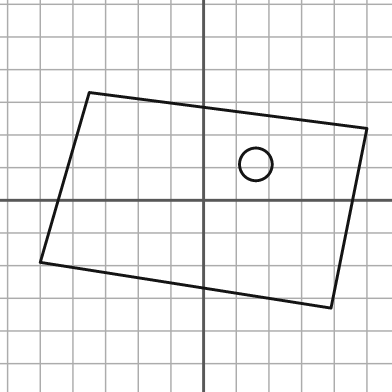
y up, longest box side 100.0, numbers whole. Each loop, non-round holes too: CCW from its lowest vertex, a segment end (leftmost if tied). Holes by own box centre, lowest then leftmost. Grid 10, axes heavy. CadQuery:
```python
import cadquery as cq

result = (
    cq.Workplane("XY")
    .moveTo(39.0, -33.0)
    .lineTo(50.0, 22.0)
    .lineTo(-35.0, 33.0)
    .lineTo(-50.0, -19.0)
    .close()
    .moveTo(16.0, 11.0)
    .circle(5.0)
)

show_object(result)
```